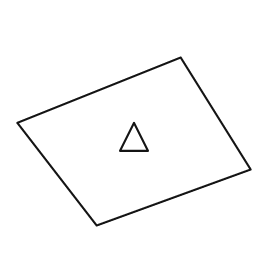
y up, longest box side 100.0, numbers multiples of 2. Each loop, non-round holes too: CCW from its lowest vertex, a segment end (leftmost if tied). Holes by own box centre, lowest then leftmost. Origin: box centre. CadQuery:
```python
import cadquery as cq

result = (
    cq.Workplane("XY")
    .moveTo(-16.0, -36.0)
    .lineTo(50.0, -12.0)
    .lineTo(20.0, 36.0)
    .lineTo(-50.0, 8.0)
    .close()
    .moveTo(-6.0, -4.0)
    .lineTo(6.0, -4.0)
    .lineTo(0.0, 8.0)
    .close()
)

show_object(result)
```